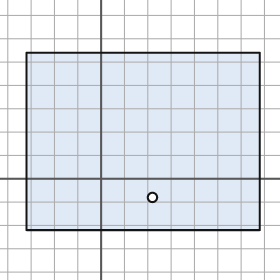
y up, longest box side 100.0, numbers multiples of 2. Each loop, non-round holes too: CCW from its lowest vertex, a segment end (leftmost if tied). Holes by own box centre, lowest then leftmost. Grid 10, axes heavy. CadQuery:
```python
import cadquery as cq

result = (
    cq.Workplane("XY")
    .moveTo(-32.0, -22.0)
    .lineTo(68.0, -22.0)
    .lineTo(68.0, 54.0)
    .lineTo(-32.0, 54.0)
    .close()
    .moveTo(22.0, -8.0)
    .circle(2.0)
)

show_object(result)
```